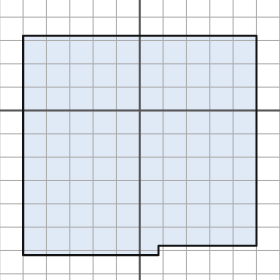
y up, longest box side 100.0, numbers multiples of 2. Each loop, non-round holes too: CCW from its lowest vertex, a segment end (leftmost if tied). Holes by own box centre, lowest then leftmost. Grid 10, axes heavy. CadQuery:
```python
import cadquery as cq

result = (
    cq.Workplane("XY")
    .moveTo(-50.0, -62.0)
    .lineTo(8.0, -62.0)
    .lineTo(8.0, -58.0)
    .lineTo(50.0, -58.0)
    .lineTo(50.0, 32.0)
    .lineTo(-50.0, 32.0)
    .close()
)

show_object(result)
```